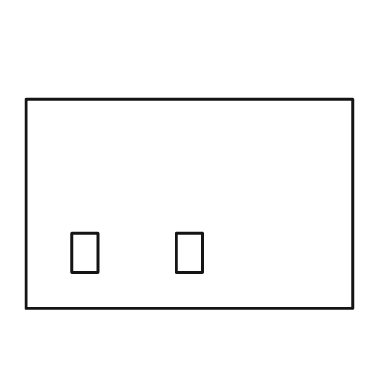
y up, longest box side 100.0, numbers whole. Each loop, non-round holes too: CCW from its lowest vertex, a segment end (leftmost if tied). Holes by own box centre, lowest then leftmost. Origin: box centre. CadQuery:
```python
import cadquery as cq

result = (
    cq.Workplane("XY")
    .moveTo(-50.0, -32.0)
    .lineTo(50.0, -32.0)
    .lineTo(50.0, 32.0)
    .lineTo(-50.0, 32.0)
    .close()
    .moveTo(-36.0, -21.0)
    .lineTo(-28.0, -21.0)
    .lineTo(-28.0, -9.0)
    .lineTo(-36.0, -9.0)
    .close()
    .moveTo(-4.0, -21.0)
    .lineTo(4.0, -21.0)
    .lineTo(4.0, -9.0)
    .lineTo(-4.0, -9.0)
    .close()
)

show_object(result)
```